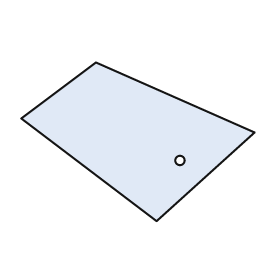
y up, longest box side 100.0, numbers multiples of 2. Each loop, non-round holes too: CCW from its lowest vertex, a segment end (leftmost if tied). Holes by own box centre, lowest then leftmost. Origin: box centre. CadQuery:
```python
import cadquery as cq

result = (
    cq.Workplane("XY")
    .moveTo(8.0, -34.0)
    .lineTo(50.0, 4.0)
    .lineTo(-18.0, 34.0)
    .lineTo(-50.0, 10.0)
    .close()
    .moveTo(18.0, -8.0)
    .circle(2.0)
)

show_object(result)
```